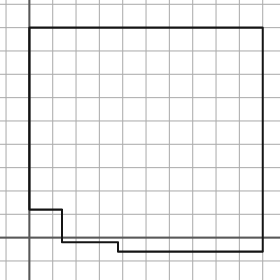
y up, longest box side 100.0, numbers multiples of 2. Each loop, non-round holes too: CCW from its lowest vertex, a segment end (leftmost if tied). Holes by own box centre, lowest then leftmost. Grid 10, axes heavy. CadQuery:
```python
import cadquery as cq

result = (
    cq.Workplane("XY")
    .moveTo(38.0, -6.0)
    .lineTo(100.0, -6.0)
    .lineTo(100.0, 90.0)
    .lineTo(0.0, 90.0)
    .lineTo(0.0, 12.0)
    .lineTo(14.0, 12.0)
    .lineTo(14.0, -2.0)
    .lineTo(38.0, -2.0)
    .close()
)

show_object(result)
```